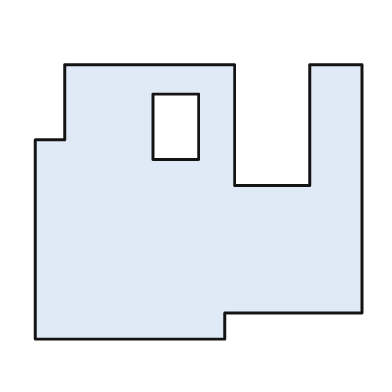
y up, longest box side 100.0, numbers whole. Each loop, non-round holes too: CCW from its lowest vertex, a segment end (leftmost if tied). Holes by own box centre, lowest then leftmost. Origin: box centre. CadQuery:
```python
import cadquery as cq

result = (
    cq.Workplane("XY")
    .moveTo(-50.0, -42.0)
    .lineTo(8.0, -42.0)
    .lineTo(8.0, -34.0)
    .lineTo(50.0, -34.0)
    .lineTo(50.0, 42.0)
    .lineTo(34.0, 42.0)
    .lineTo(34.0, 5.0)
    .lineTo(11.0, 5.0)
    .lineTo(11.0, 42.0)
    .lineTo(-41.0, 42.0)
    .lineTo(-41.0, 19.0)
    .lineTo(-50.0, 19.0)
    .close()
    .moveTo(-14.0, 13.0)
    .lineTo(0.0, 13.0)
    .lineTo(0.0, 33.0)
    .lineTo(-14.0, 33.0)
    .close()
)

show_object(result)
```